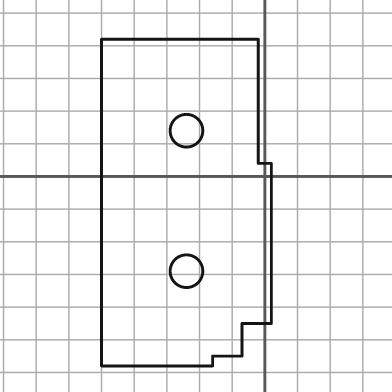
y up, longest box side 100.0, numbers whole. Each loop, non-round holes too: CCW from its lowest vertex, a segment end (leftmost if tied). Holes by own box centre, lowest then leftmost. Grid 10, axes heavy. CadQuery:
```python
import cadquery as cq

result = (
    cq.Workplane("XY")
    .moveTo(-50.0, -58.0)
    .lineTo(-16.0, -58.0)
    .lineTo(-16.0, -55.0)
    .lineTo(-7.0, -55.0)
    .lineTo(-7.0, -45.0)
    .lineTo(2.0, -45.0)
    .lineTo(2.0, 4.0)
    .lineTo(-2.0, 4.0)
    .lineTo(-2.0, 42.0)
    .lineTo(-50.0, 42.0)
    .close()
    .moveTo(-24.0, -29.0)
    .circle(5.0)
    .moveTo(-24.0, 14.0)
    .circle(5.0)
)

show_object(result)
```